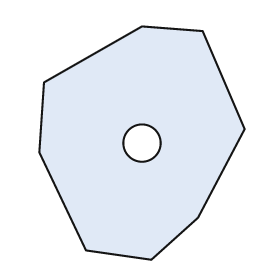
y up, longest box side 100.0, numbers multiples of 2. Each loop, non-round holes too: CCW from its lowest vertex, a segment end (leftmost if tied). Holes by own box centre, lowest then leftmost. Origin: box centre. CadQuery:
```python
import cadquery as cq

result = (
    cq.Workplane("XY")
    .moveTo(4.0, -50.0)
    .lineTo(24.0, -32.0)
    .lineTo(44.0, 6.0)
    .lineTo(26.0, 48.0)
    .lineTo(0.0, 50.0)
    .lineTo(-42.0, 26.0)
    .lineTo(-44.0, -4.0)
    .lineTo(-24.0, -46.0)
    .close()
    .moveTo(0.0, 0.0)
    .circle(8.0)
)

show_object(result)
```